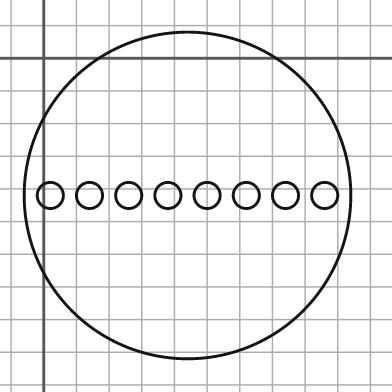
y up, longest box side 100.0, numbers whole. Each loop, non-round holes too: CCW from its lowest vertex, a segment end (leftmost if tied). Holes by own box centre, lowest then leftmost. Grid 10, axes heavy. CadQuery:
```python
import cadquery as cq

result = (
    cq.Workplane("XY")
    .moveTo(44.0, -42.0)
    .circle(50.0)
    .moveTo(2.0, -42.0)
    .circle(4.0)
    .moveTo(14.0, -42.0)
    .circle(4.0)
    .moveTo(26.0, -42.0)
    .circle(4.0)
    .moveTo(38.0, -42.0)
    .circle(4.0)
    .moveTo(50.0, -42.0)
    .circle(4.0)
    .moveTo(62.0, -42.0)
    .circle(4.0)
    .moveTo(74.0, -42.0)
    .circle(4.0)
    .moveTo(86.0, -42.0)
    .circle(4.0)
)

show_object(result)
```